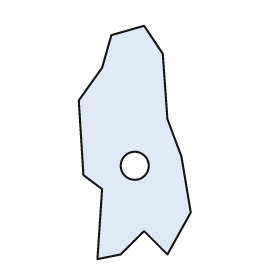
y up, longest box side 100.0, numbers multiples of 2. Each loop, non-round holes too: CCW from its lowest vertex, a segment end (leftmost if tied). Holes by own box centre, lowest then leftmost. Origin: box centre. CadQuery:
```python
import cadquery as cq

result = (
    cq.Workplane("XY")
    .moveTo(-16.0, -50.0)
    .lineTo(-6.0, -48.0)
    .lineTo(4.0, -38.0)
    .lineTo(14.0, -48.0)
    .lineTo(24.0, -30.0)
    .lineTo(20.0, -6.0)
    .lineTo(14.0, 10.0)
    .lineTo(12.0, 38.0)
    .lineTo(4.0, 50.0)
    .lineTo(-10.0, 46.0)
    .lineTo(-14.0, 32.0)
    .lineTo(-24.0, 18.0)
    .lineTo(-22.0, -14.0)
    .lineTo(-14.0, -20.0)
    .close()
    .moveTo(0.0, -10.0)
    .circle(6.0)
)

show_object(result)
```